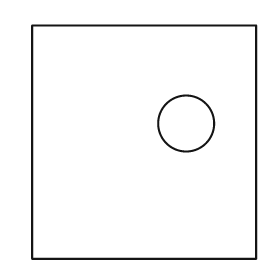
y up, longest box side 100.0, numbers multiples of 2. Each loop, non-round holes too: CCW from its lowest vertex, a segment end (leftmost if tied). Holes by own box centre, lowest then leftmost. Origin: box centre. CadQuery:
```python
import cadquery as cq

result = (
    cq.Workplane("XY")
    .moveTo(-48.0, -50.0)
    .lineTo(48.0, -50.0)
    .lineTo(48.0, 50.0)
    .lineTo(-48.0, 50.0)
    .close()
    .moveTo(18.0, 8.0)
    .circle(12.0)
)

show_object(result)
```